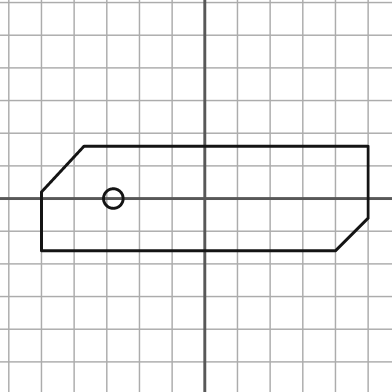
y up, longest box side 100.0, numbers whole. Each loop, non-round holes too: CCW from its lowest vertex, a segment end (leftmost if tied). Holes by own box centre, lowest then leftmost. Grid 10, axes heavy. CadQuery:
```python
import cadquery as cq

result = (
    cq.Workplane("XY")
    .moveTo(-50.0, -16.0)
    .lineTo(40.0, -16.0)
    .lineTo(50.0, -6.0)
    .lineTo(50.0, 16.0)
    .lineTo(-37.0, 16.0)
    .lineTo(-50.0, 2.0)
    .close()
    .moveTo(-28.0, 0.0)
    .circle(3.0)
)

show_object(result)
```